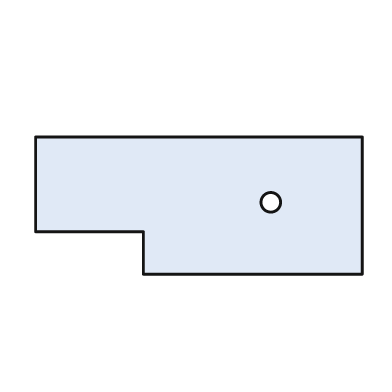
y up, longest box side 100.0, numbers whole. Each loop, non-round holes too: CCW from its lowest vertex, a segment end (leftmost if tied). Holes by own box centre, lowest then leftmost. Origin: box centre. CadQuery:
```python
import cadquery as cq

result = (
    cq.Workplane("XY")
    .moveTo(-17.0, -21.0)
    .lineTo(50.0, -21.0)
    .lineTo(50.0, 21.0)
    .lineTo(-50.0, 21.0)
    .lineTo(-50.0, -8.0)
    .lineTo(-17.0, -8.0)
    .close()
    .moveTo(22.0, 1.0)
    .circle(3.0)
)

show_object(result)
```